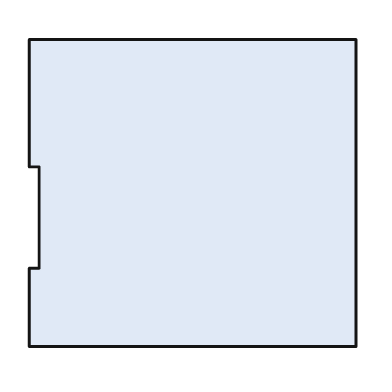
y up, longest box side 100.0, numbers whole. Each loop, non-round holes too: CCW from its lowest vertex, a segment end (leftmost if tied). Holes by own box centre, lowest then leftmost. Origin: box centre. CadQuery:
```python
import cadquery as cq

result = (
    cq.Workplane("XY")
    .moveTo(-50.0, -47.0)
    .lineTo(50.0, -47.0)
    .lineTo(50.0, 47.0)
    .lineTo(-50.0, 47.0)
    .lineTo(-50.0, 8.0)
    .lineTo(-47.0, 8.0)
    .lineTo(-47.0, -23.0)
    .lineTo(-50.0, -23.0)
    .close()
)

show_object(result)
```